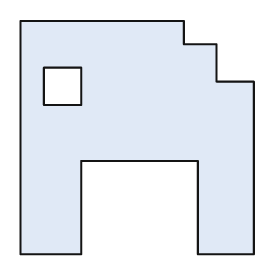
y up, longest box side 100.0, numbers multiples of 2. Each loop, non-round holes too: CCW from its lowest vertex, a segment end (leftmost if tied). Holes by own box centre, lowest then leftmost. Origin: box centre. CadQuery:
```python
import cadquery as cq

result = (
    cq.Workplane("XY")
    .moveTo(-50.0, -50.0)
    .lineTo(-24.0, -50.0)
    .lineTo(-24.0, -10.0)
    .lineTo(26.0, -10.0)
    .lineTo(26.0, -50.0)
    .lineTo(50.0, -50.0)
    .lineTo(50.0, 24.0)
    .lineTo(34.0, 24.0)
    .lineTo(34.0, 40.0)
    .lineTo(20.0, 40.0)
    .lineTo(20.0, 50.0)
    .lineTo(-50.0, 50.0)
    .close()
    .moveTo(-40.0, 14.0)
    .lineTo(-24.0, 14.0)
    .lineTo(-24.0, 30.0)
    .lineTo(-40.0, 30.0)
    .close()
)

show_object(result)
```